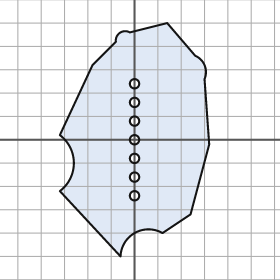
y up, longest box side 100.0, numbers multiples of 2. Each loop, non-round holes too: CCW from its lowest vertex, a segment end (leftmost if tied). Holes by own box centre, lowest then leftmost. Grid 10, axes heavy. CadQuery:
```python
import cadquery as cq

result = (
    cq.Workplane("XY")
    .moveTo(-6.0, -50.0)
    .threePointArc((0.0, -40.0), (12.0, -40.0))
    .lineTo(24.0, -32.0)
    .lineTo(32.0, -2.0)
    .lineTo(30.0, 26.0)
    .threePointArc((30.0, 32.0), (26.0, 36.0))
    .lineTo(14.0, 50.0)
    .lineTo(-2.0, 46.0)
    .threePointArc((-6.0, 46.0), (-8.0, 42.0))
    .lineTo(-18.0, 32.0)
    .lineTo(-32.0, 2.0)
    .threePointArc((-26.0, -10.0), (-32.0, -22.0))
    .close()
    .moveTo(0.0, -24.0)
    .circle(2.0)
    .moveTo(0.0, -16.0)
    .circle(2.0)
    .moveTo(0.0, -8.0)
    .circle(2.0)
    .moveTo(0.0, 0.0)
    .circle(2.0)
    .moveTo(0.0, 8.0)
    .circle(2.0)
    .moveTo(0.0, 16.0)
    .circle(2.0)
    .moveTo(0.0, 24.0)
    .circle(2.0)
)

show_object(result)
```